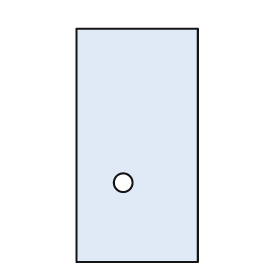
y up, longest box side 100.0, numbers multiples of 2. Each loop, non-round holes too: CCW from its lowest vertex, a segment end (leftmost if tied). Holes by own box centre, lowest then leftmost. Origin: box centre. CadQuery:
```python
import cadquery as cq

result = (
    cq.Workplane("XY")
    .moveTo(-26.0, -50.0)
    .lineTo(26.0, -50.0)
    .lineTo(26.0, 50.0)
    .lineTo(-26.0, 50.0)
    .close()
    .moveTo(-6.0, -16.0)
    .circle(4.0)
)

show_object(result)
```